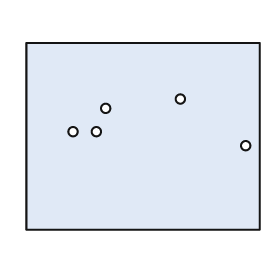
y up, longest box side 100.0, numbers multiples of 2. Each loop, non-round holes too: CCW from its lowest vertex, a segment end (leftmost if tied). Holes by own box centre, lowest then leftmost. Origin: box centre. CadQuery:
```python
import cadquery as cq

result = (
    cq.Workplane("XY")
    .moveTo(-50.0, -40.0)
    .lineTo(50.0, -40.0)
    .lineTo(50.0, 40.0)
    .lineTo(-50.0, 40.0)
    .close()
    .moveTo(44.0, -4.0)
    .circle(2.0)
    .moveTo(-30.0, 2.0)
    .circle(2.0)
    .moveTo(-20.0, 2.0)
    .circle(2.0)
    .moveTo(-16.0, 12.0)
    .circle(2.0)
    .moveTo(16.0, 16.0)
    .circle(2.0)
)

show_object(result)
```